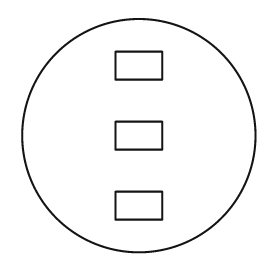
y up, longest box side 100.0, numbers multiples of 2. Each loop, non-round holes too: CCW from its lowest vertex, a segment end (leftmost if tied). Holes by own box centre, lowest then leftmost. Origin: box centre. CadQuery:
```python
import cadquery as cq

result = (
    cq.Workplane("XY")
    .moveTo(0.0, 0.0)
    .circle(50.0)
    .moveTo(-10.0, -36.0)
    .lineTo(10.0, -36.0)
    .lineTo(10.0, -24.0)
    .lineTo(-10.0, -24.0)
    .close()
    .moveTo(-10.0, -6.0)
    .lineTo(10.0, -6.0)
    .lineTo(10.0, 6.0)
    .lineTo(-10.0, 6.0)
    .close()
    .moveTo(-10.0, 24.0)
    .lineTo(10.0, 24.0)
    .lineTo(10.0, 36.0)
    .lineTo(-10.0, 36.0)
    .close()
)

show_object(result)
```